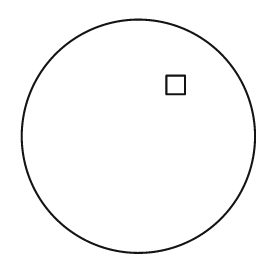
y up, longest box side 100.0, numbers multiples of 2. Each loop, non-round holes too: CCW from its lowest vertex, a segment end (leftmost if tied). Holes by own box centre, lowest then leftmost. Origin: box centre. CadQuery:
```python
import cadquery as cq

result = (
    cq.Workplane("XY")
    .moveTo(0.0, 0.0)
    .circle(50.0)
    .moveTo(12.0, 18.0)
    .lineTo(20.0, 18.0)
    .lineTo(20.0, 26.0)
    .lineTo(12.0, 26.0)
    .close()
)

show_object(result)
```